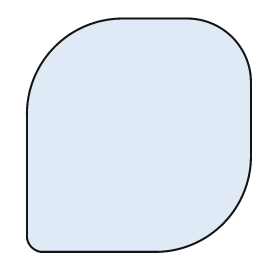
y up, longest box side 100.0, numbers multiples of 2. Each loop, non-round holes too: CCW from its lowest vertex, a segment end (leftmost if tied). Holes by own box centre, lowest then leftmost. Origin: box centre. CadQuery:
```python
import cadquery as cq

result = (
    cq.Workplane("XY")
    .moveTo(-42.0, -50.0)
    .lineTo(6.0, -50.0)
    .threePointArc((36.0, -38.0), (48.0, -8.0))
    .lineTo(48.0, 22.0)
    .threePointArc((40.0, 42.0), (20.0, 50.0))
    .lineTo(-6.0, 50.0)
    .threePointArc((-36.0, 38.0), (-48.0, 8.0))
    .lineTo(-48.0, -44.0)
    .threePointArc((-46.0, -48.0), (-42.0, -50.0))
    .close()
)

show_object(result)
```